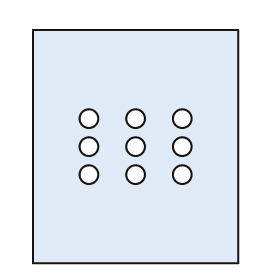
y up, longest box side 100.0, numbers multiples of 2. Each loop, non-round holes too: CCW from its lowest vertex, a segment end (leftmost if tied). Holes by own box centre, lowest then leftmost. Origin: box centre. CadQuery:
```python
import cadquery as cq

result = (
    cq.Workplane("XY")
    .moveTo(-44.0, -50.0)
    .lineTo(44.0, -50.0)
    .lineTo(44.0, 50.0)
    .lineTo(-44.0, 50.0)
    .close()
    .moveTo(-20.0, -12.0)
    .circle(4.0)
    .moveTo(0.0, -12.0)
    .circle(4.0)
    .moveTo(20.0, -12.0)
    .circle(4.0)
    .moveTo(-20.0, 0.0)
    .circle(4.0)
    .moveTo(0.0, 0.0)
    .circle(4.0)
    .moveTo(20.0, 0.0)
    .circle(4.0)
    .moveTo(-20.0, 12.0)
    .circle(4.0)
    .moveTo(0.0, 12.0)
    .circle(4.0)
    .moveTo(20.0, 12.0)
    .circle(4.0)
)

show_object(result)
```